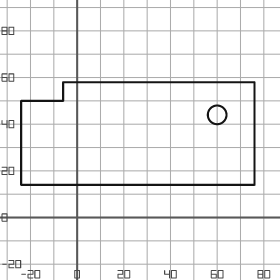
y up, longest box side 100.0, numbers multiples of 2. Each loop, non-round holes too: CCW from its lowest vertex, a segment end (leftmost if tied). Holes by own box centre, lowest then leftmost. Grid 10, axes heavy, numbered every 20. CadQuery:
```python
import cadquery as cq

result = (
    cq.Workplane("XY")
    .moveTo(-24.0, 14.0)
    .lineTo(76.0, 14.0)
    .lineTo(76.0, 58.0)
    .lineTo(-6.0, 58.0)
    .lineTo(-6.0, 50.0)
    .lineTo(-24.0, 50.0)
    .close()
    .moveTo(60.0, 44.0)
    .circle(4.0)
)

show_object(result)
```